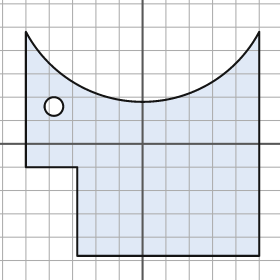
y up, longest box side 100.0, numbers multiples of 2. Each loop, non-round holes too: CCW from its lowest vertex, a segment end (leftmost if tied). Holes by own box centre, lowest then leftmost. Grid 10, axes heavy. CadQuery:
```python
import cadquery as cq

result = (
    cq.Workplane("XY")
    .moveTo(-28.0, -48.0)
    .lineTo(50.0, -48.0)
    .lineTo(50.0, 48.0)
    .threePointArc((0.0, 18.0), (-50.0, 48.0))
    .lineTo(-50.0, -10.0)
    .lineTo(-28.0, -10.0)
    .close()
    .moveTo(-38.0, 16.0)
    .circle(4.0)
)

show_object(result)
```